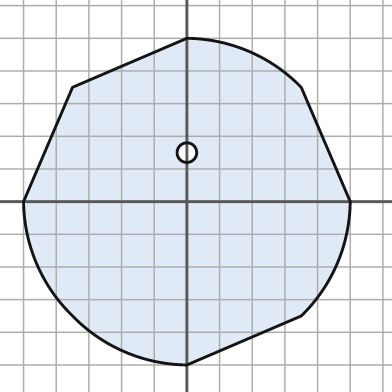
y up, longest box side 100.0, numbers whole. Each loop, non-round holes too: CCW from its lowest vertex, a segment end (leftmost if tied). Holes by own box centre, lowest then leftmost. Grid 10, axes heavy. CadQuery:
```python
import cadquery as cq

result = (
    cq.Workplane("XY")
    .moveTo(0.0, -50.0)
    .lineTo(35.0, -35.0)
    .threePointArc((46.0, -19.0), (50.0, 0.0))
    .lineTo(35.0, 35.0)
    .threePointArc((19.0, 46.0), (0.0, 50.0))
    .lineTo(-35.0, 35.0)
    .lineTo(-50.0, 0.0)
    .threePointArc((-46.0, -19.0), (-35.0, -35.0))
    .threePointArc((-19.0, -46.0), (0.0, -50.0))
    .close()
    .moveTo(0.0, 15.0)
    .circle(3.0)
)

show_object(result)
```